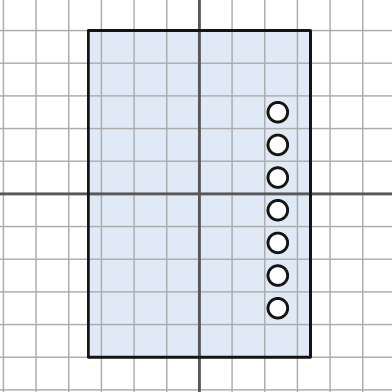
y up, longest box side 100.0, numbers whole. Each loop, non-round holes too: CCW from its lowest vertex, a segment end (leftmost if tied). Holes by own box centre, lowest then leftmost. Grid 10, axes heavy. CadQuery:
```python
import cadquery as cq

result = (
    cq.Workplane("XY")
    .moveTo(-34.0, -50.0)
    .lineTo(34.0, -50.0)
    .lineTo(34.0, 50.0)
    .lineTo(-34.0, 50.0)
    .close()
    .moveTo(24.0, -35.0)
    .circle(3.0)
    .moveTo(24.0, -25.0)
    .circle(3.0)
    .moveTo(24.0, -15.0)
    .circle(3.0)
    .moveTo(24.0, -5.0)
    .circle(3.0)
    .moveTo(24.0, 5.0)
    .circle(3.0)
    .moveTo(24.0, 15.0)
    .circle(3.0)
    .moveTo(24.0, 25.0)
    .circle(3.0)
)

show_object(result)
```